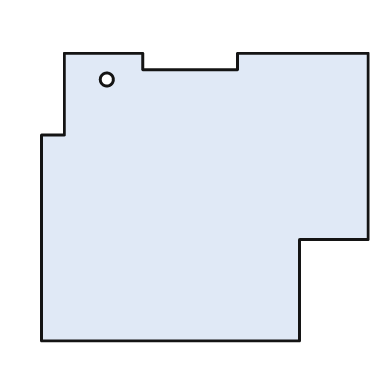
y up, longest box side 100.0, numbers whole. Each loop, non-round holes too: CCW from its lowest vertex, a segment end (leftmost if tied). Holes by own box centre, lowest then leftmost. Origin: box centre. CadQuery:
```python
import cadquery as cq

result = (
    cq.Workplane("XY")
    .moveTo(-50.0, -44.0)
    .lineTo(29.0, -44.0)
    .lineTo(29.0, -13.0)
    .lineTo(50.0, -13.0)
    .lineTo(50.0, 44.0)
    .lineTo(10.0, 44.0)
    .lineTo(10.0, 39.0)
    .lineTo(-19.0, 39.0)
    .lineTo(-19.0, 44.0)
    .lineTo(-43.0, 44.0)
    .lineTo(-43.0, 19.0)
    .lineTo(-50.0, 19.0)
    .close()
    .moveTo(-30.0, 36.0)
    .circle(2.0)
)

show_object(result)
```